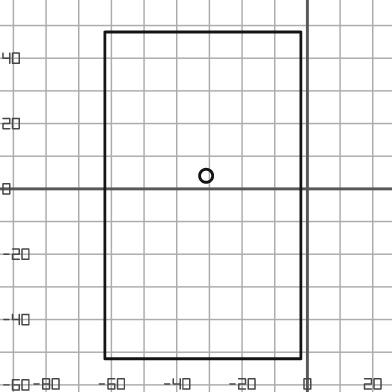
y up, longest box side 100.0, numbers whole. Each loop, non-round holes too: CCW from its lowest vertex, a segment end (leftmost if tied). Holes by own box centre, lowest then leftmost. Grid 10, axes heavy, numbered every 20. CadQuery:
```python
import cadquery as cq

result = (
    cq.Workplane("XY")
    .moveTo(-62.0, -52.0)
    .lineTo(-2.0, -52.0)
    .lineTo(-2.0, 48.0)
    .lineTo(-62.0, 48.0)
    .close()
    .moveTo(-31.0, 4.0)
    .circle(2.0)
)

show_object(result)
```